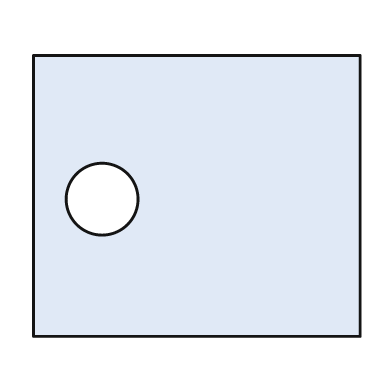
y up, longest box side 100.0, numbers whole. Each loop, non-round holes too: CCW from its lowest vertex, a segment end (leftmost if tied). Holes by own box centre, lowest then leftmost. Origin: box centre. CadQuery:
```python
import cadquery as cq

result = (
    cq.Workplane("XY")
    .moveTo(-50.0, -43.0)
    .lineTo(50.0, -43.0)
    .lineTo(50.0, 43.0)
    .lineTo(-50.0, 43.0)
    .close()
    .moveTo(-29.0, -1.0)
    .circle(11.0)
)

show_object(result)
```